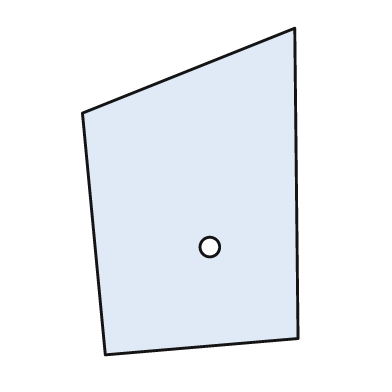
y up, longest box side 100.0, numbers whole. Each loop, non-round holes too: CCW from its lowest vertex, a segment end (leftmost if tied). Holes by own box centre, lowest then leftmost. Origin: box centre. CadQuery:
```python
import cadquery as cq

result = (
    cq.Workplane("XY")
    .moveTo(-26.0, -50.0)
    .lineTo(33.0, -45.0)
    .lineTo(32.0, 50.0)
    .lineTo(-33.0, 24.0)
    .close()
    .moveTo(6.0, -17.0)
    .circle(3.0)
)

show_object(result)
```